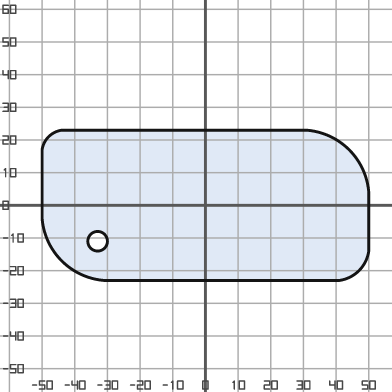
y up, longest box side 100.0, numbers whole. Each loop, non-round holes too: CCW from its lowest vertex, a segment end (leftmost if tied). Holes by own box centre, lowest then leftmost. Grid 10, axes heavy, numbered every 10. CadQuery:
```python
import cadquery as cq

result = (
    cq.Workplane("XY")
    .moveTo(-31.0, -23.0)
    .lineTo(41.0, -23.0)
    .threePointArc((47.0, -20.0), (50.0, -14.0))
    .lineTo(50.0, 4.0)
    .threePointArc((44.0, 17.0), (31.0, 23.0))
    .lineTo(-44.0, 23.0)
    .threePointArc((-48.0, 21.0), (-50.0, 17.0))
    .lineTo(-50.0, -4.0)
    .threePointArc((-44.0, -17.0), (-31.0, -23.0))
    .close()
    .moveTo(-33.0, -11.0)
    .circle(3.0)
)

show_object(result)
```